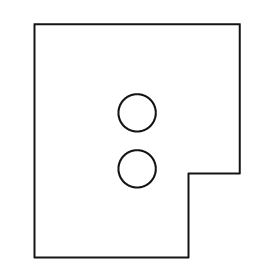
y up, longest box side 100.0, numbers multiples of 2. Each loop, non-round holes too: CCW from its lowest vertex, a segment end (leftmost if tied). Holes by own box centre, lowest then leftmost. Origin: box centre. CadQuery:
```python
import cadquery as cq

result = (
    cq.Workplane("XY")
    .moveTo(-44.0, -50.0)
    .lineTo(22.0, -50.0)
    .lineTo(22.0, -14.0)
    .lineTo(44.0, -14.0)
    .lineTo(44.0, 50.0)
    .lineTo(-44.0, 50.0)
    .close()
    .moveTo(0.0, -12.0)
    .circle(8.0)
    .moveTo(0.0, 12.0)
    .circle(8.0)
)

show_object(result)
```